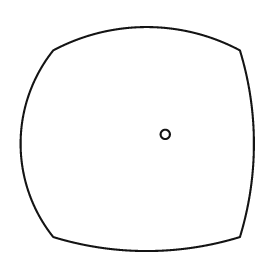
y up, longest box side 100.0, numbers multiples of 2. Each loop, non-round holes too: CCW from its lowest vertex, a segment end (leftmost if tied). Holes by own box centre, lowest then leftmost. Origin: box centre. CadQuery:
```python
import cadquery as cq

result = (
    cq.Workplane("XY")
    .moveTo(-36.0, -42.0)
    .threePointArc((4.0, -48.0), (44.0, -42.0))
    .threePointArc((50.0, -2.0), (44.0, 38.0))
    .threePointArc((4.0, 48.0), (-36.0, 38.0))
    .threePointArc((-50.0, -2.0), (-36.0, -42.0))
    .close()
    .moveTo(12.0, 2.0)
    .circle(2.0)
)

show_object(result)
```